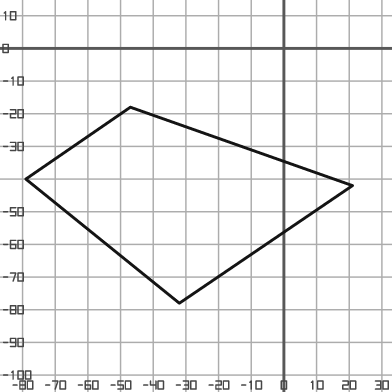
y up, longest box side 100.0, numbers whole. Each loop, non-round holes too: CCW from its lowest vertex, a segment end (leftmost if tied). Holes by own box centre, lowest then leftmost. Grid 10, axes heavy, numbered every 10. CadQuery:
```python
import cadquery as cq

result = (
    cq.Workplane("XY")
    .moveTo(-32.0, -78.0)
    .lineTo(21.0, -42.0)
    .lineTo(-47.0, -18.0)
    .lineTo(-79.0, -40.0)
    .close()
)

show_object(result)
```